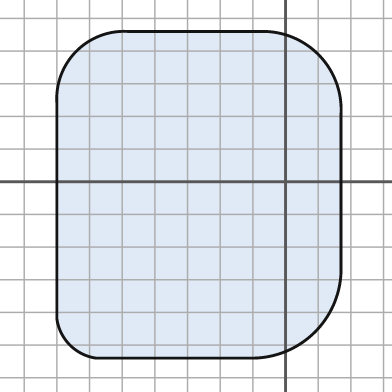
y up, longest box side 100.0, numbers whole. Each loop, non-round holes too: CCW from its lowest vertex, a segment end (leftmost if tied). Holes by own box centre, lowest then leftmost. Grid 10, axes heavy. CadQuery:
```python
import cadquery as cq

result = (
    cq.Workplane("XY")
    .moveTo(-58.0, -54.0)
    .lineTo(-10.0, -54.0)
    .threePointArc((9.0, -46.0), (17.0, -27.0))
    .lineTo(17.0, 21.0)
    .threePointArc((10.0, 39.0), (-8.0, 46.0))
    .lineTo(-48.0, 46.0)
    .threePointArc((-64.0, 40.0), (-70.0, 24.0))
    .lineTo(-70.0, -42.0)
    .threePointArc((-66.0, -50.0), (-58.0, -54.0))
    .close()
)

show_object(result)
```